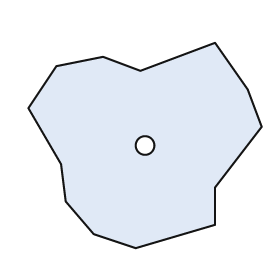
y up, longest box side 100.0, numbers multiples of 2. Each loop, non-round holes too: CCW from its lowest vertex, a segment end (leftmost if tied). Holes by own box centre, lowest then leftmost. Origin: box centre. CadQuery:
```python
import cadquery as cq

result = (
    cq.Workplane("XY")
    .moveTo(-4.0, -44.0)
    .lineTo(30.0, -34.0)
    .lineTo(30.0, -18.0)
    .lineTo(50.0, 8.0)
    .lineTo(44.0, 24.0)
    .lineTo(30.0, 44.0)
    .lineTo(-2.0, 32.0)
    .lineTo(-18.0, 38.0)
    .lineTo(-38.0, 34.0)
    .lineTo(-50.0, 16.0)
    .lineTo(-36.0, -8.0)
    .lineTo(-34.0, -24.0)
    .lineTo(-22.0, -38.0)
    .close()
    .moveTo(0.0, 0.0)
    .circle(4.0)
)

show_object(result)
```